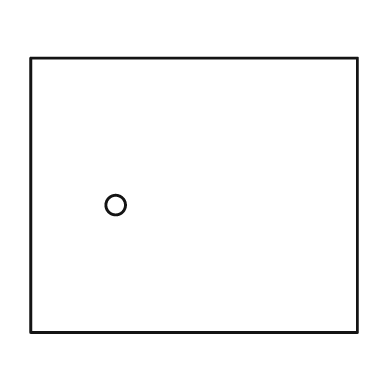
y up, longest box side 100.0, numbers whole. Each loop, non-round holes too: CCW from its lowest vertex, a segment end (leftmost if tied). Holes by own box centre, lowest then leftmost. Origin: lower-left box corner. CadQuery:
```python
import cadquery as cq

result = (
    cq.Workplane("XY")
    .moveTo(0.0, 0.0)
    .lineTo(100.0, 0.0)
    .lineTo(100.0, 84.0)
    .lineTo(0.0, 84.0)
    .close()
    .moveTo(26.0, 39.0)
    .circle(3.0)
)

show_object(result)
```